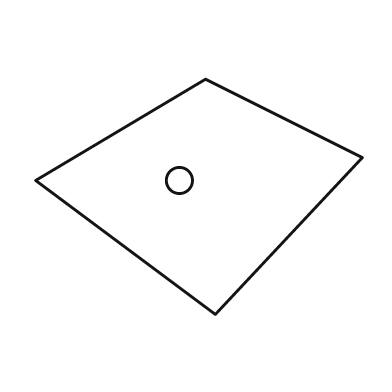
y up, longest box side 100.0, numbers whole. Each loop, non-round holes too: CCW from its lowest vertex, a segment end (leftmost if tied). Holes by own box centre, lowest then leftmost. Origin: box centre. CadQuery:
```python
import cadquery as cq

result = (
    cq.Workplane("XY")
    .moveTo(5.0, -36.0)
    .lineTo(50.0, 12.0)
    .lineTo(2.0, 36.0)
    .lineTo(-50.0, 5.0)
    .close()
    .moveTo(-6.0, 5.0)
    .circle(4.0)
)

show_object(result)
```